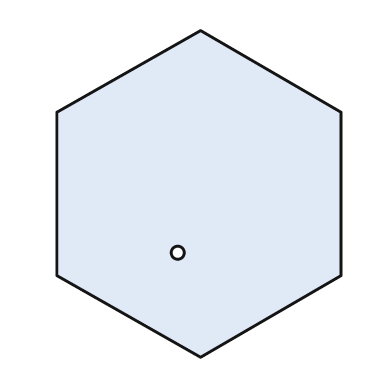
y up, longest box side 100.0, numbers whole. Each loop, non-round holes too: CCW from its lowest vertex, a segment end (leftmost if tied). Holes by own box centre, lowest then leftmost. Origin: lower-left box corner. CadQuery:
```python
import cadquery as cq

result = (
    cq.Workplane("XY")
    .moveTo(44.0, 0.0)
    .lineTo(87.0, 25.0)
    .lineTo(87.0, 75.0)
    .lineTo(44.0, 100.0)
    .lineTo(0.0, 75.0)
    .lineTo(0.0, 25.0)
    .close()
    .moveTo(37.0, 32.0)
    .circle(2.0)
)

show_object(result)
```